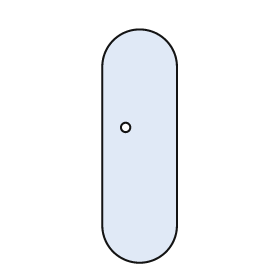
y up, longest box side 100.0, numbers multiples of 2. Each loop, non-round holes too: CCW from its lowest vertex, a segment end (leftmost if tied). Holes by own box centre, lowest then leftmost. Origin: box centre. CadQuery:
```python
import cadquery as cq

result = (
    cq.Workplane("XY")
    .moveTo(-16.0, -34.0)
    .threePointArc((0.0, -50.0), (16.0, -34.0))
    .lineTo(16.0, 34.0)
    .threePointArc((0.0, 50.0), (-16.0, 34.0))
    .close()
    .moveTo(-6.0, 8.0)
    .circle(2.0)
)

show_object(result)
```